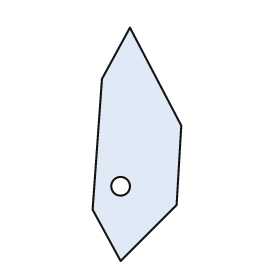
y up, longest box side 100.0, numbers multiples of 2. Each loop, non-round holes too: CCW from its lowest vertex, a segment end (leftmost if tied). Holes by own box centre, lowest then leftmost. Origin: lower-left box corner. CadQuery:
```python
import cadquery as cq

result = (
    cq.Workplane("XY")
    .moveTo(12.0, 0.0)
    .lineTo(36.0, 24.0)
    .lineTo(38.0, 58.0)
    .lineTo(16.0, 100.0)
    .lineTo(4.0, 78.0)
    .lineTo(0.0, 22.0)
    .close()
    .moveTo(12.0, 32.0)
    .circle(4.0)
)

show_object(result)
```